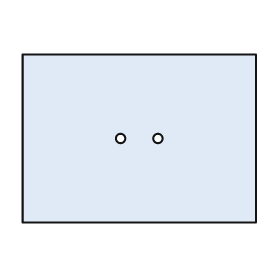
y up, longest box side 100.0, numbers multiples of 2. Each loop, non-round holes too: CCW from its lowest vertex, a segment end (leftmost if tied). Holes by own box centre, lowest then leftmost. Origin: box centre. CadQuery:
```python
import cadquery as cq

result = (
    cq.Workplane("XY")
    .moveTo(-50.0, -36.0)
    .lineTo(50.0, -36.0)
    .lineTo(50.0, 36.0)
    .lineTo(-50.0, 36.0)
    .close()
    .moveTo(-8.0, 0.0)
    .circle(2.0)
    .moveTo(8.0, 0.0)
    .circle(2.0)
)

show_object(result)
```